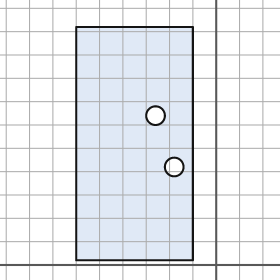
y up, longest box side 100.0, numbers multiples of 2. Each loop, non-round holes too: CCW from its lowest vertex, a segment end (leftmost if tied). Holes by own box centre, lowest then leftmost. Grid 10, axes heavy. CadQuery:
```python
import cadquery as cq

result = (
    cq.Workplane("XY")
    .moveTo(-60.0, 2.0)
    .lineTo(-10.0, 2.0)
    .lineTo(-10.0, 102.0)
    .lineTo(-60.0, 102.0)
    .close()
    .moveTo(-18.0, 42.0)
    .circle(4.0)
    .moveTo(-26.0, 64.0)
    .circle(4.0)
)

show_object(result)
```